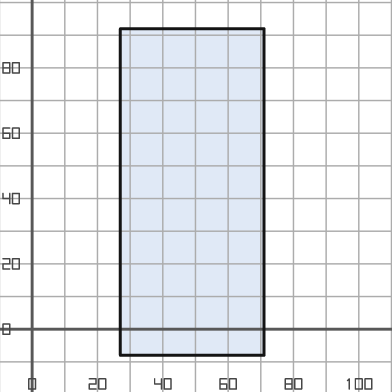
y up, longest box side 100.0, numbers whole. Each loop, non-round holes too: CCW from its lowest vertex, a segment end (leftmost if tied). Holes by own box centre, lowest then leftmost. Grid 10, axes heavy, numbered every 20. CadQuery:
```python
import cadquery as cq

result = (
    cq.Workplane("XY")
    .moveTo(27.0, -8.0)
    .lineTo(71.0, -8.0)
    .lineTo(71.0, 92.0)
    .lineTo(27.0, 92.0)
    .close()
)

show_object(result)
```